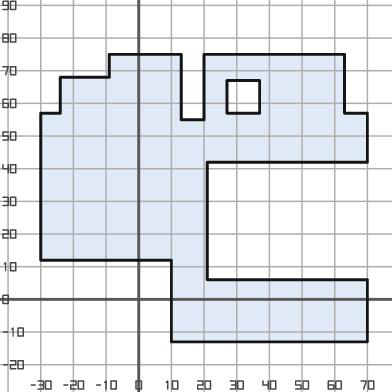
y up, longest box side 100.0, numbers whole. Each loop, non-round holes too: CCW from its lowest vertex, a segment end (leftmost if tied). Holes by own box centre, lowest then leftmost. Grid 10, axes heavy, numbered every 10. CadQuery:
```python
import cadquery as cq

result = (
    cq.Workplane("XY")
    .moveTo(10.0, -13.0)
    .lineTo(70.0, -13.0)
    .lineTo(70.0, 6.0)
    .lineTo(21.0, 6.0)
    .lineTo(21.0, 42.0)
    .lineTo(70.0, 42.0)
    .lineTo(70.0, 57.0)
    .lineTo(63.0, 57.0)
    .lineTo(63.0, 75.0)
    .lineTo(20.0, 75.0)
    .lineTo(20.0, 55.0)
    .lineTo(13.0, 55.0)
    .lineTo(13.0, 75.0)
    .lineTo(-9.0, 75.0)
    .lineTo(-9.0, 68.0)
    .lineTo(-24.0, 68.0)
    .lineTo(-24.0, 57.0)
    .lineTo(-30.0, 57.0)
    .lineTo(-30.0, 12.0)
    .lineTo(10.0, 12.0)
    .close()
    .moveTo(27.0, 57.0)
    .lineTo(37.0, 57.0)
    .lineTo(37.0, 67.0)
    .lineTo(27.0, 67.0)
    .close()
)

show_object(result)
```